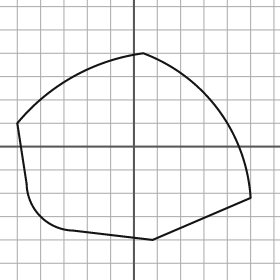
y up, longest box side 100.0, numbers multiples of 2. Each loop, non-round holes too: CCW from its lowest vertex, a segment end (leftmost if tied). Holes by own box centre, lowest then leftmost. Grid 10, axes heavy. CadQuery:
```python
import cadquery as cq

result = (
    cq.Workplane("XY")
    .moveTo(8.0, -40.0)
    .lineTo(50.0, -22.0)
    .threePointArc((36.0, 16.0), (4.0, 40.0))
    .threePointArc((-26.0, 30.0), (-50.0, 10.0))
    .lineTo(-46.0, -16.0)
    .threePointArc((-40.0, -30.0), (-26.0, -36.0))
    .close()
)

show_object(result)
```